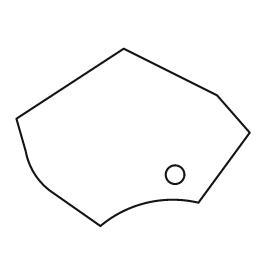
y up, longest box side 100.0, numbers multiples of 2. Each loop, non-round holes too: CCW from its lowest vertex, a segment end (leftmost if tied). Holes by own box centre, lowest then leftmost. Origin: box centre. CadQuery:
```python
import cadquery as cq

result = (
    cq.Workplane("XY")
    .moveTo(-14.0, -38.0)
    .threePointArc((6.0, -28.0), (28.0, -28.0))
    .lineTo(50.0, 2.0)
    .lineTo(36.0, 18.0)
    .lineTo(-4.0, 38.0)
    .lineTo(-50.0, 8.0)
    .lineTo(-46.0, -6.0)
    .threePointArc((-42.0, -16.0), (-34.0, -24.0))
    .close()
    .moveTo(18.0, -16.0)
    .circle(4.0)
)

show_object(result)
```